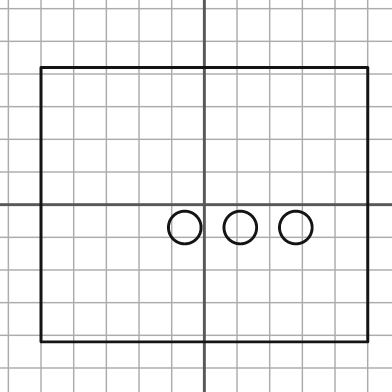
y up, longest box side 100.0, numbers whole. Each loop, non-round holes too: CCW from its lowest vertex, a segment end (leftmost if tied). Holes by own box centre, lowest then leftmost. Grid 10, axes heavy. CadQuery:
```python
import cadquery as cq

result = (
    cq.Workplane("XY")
    .moveTo(-50.0, -42.0)
    .lineTo(50.0, -42.0)
    .lineTo(50.0, 42.0)
    .lineTo(-50.0, 42.0)
    .close()
    .moveTo(-6.0, -7.0)
    .circle(5.0)
    .moveTo(11.0, -7.0)
    .circle(5.0)
    .moveTo(28.0, -7.0)
    .circle(5.0)
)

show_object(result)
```